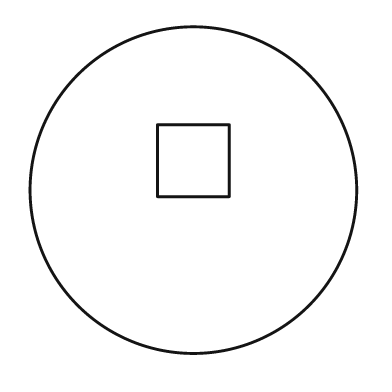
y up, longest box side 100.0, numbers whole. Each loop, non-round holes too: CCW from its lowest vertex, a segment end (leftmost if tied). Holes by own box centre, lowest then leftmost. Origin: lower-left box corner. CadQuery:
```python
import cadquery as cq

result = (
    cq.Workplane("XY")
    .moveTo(50.0, 50.0)
    .circle(50.0)
    .moveTo(39.0, 48.0)
    .lineTo(61.0, 48.0)
    .lineTo(61.0, 70.0)
    .lineTo(39.0, 70.0)
    .close()
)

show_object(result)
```